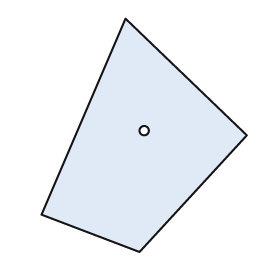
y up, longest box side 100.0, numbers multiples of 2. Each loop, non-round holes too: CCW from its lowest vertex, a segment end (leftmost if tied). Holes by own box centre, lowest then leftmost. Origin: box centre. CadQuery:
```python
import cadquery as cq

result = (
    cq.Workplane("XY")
    .moveTo(-2.0, -50.0)
    .lineTo(44.0, 0.0)
    .lineTo(-8.0, 50.0)
    .lineTo(-44.0, -34.0)
    .close()
    .moveTo(0.0, 2.0)
    .circle(2.0)
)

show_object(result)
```